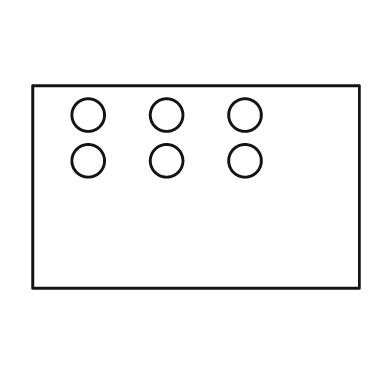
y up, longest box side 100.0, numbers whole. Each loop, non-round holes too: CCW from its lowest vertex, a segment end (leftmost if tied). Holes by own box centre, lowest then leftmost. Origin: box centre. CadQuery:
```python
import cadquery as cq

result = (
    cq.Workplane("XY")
    .moveTo(-50.0, -31.0)
    .lineTo(50.0, -31.0)
    .lineTo(50.0, 31.0)
    .lineTo(-50.0, 31.0)
    .close()
    .moveTo(-33.0, 8.0)
    .circle(5.0)
    .moveTo(-9.0, 8.0)
    .circle(5.0)
    .moveTo(15.0, 8.0)
    .circle(5.0)
    .moveTo(-33.0, 22.0)
    .circle(5.0)
    .moveTo(-9.0, 22.0)
    .circle(5.0)
    .moveTo(15.0, 22.0)
    .circle(5.0)
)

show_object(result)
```